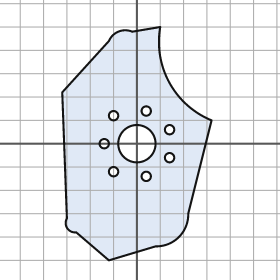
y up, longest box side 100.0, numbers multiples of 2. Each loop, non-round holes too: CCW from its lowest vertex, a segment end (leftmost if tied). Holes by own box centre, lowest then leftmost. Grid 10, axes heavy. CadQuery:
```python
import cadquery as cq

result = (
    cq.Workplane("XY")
    .moveTo(-12.0, -50.0)
    .lineTo(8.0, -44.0)
    .threePointArc((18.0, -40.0), (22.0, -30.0))
    .lineTo(32.0, 10.0)
    .threePointArc((14.0, 26.0), (10.0, 50.0))
    .lineTo(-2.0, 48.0)
    .threePointArc((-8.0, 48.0), (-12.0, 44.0))
    .lineTo(-32.0, 22.0)
    .lineTo(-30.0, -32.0)
    .threePointArc((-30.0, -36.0), (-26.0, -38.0))
    .close()
    .moveTo(4.0, -14.0)
    .circle(2.0)
    .moveTo(-10.0, -12.0)
    .circle(2.0)
    .moveTo(14.0, -6.0)
    .circle(2.0)
    .moveTo(-14.0, 0.0)
    .circle(2.0)
    .moveTo(0.0, 0.0)
    .circle(8.0)
    .moveTo(14.0, 6.0)
    .circle(2.0)
    .moveTo(-10.0, 12.0)
    .circle(2.0)
    .moveTo(4.0, 14.0)
    .circle(2.0)
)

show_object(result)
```